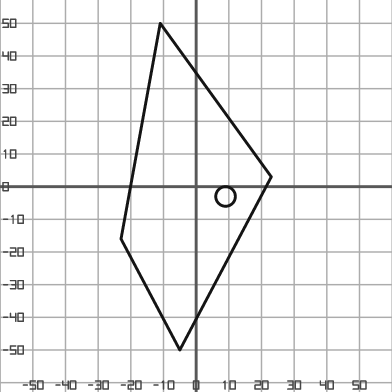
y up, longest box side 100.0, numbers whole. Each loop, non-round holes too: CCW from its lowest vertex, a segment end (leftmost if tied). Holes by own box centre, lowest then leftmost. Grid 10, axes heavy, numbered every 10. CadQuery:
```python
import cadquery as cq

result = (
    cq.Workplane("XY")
    .moveTo(-5.0, -50.0)
    .lineTo(23.0, 3.0)
    .lineTo(-11.0, 50.0)
    .lineTo(-23.0, -16.0)
    .close()
    .moveTo(9.0, -3.0)
    .circle(3.0)
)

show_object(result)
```